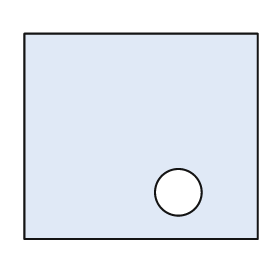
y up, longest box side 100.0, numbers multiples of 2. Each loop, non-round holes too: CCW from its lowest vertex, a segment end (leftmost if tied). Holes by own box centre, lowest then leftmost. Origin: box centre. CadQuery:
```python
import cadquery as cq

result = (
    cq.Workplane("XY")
    .moveTo(-50.0, -44.0)
    .lineTo(50.0, -44.0)
    .lineTo(50.0, 44.0)
    .lineTo(-50.0, 44.0)
    .close()
    .moveTo(16.0, -24.0)
    .circle(10.0)
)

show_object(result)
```